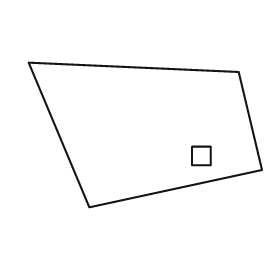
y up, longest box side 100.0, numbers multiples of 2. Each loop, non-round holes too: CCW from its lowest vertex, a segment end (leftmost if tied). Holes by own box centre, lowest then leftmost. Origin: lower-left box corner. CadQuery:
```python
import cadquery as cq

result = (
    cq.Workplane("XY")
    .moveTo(26.0, 0.0)
    .lineTo(100.0, 16.0)
    .lineTo(90.0, 58.0)
    .lineTo(0.0, 62.0)
    .close()
    .moveTo(70.0, 18.0)
    .lineTo(78.0, 18.0)
    .lineTo(78.0, 26.0)
    .lineTo(70.0, 26.0)
    .close()
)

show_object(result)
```